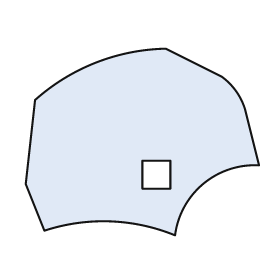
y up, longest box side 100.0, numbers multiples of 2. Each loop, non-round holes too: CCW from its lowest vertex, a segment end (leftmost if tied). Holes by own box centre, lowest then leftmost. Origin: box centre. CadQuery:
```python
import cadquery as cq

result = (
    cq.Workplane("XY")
    .moveTo(14.0, -40.0)
    .threePointArc((26.0, -18.0), (50.0, -10.0))
    .lineTo(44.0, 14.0)
    .threePointArc((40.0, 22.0), (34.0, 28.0))
    .lineTo(10.0, 40.0)
    .threePointArc((-20.0, 34.0), (-46.0, 18.0))
    .lineTo(-50.0, -18.0)
    .lineTo(-42.0, -38.0)
    .threePointArc((-14.0, -34.0), (14.0, -40.0))
    .close()
    .moveTo(0.0, -20.0)
    .lineTo(12.0, -20.0)
    .lineTo(12.0, -8.0)
    .lineTo(0.0, -8.0)
    .close()
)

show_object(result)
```